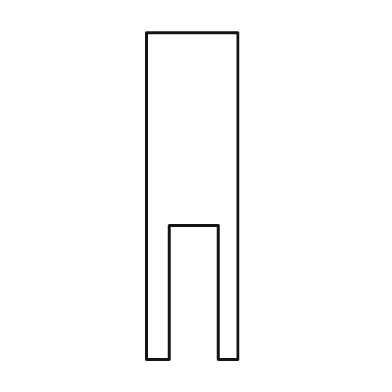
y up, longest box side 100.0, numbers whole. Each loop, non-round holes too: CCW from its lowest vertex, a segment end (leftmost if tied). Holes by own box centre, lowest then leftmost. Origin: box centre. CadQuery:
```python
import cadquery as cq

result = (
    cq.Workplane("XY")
    .moveTo(-14.0, -50.0)
    .lineTo(-7.0, -50.0)
    .lineTo(-7.0, -9.0)
    .lineTo(8.0, -9.0)
    .lineTo(8.0, -50.0)
    .lineTo(14.0, -50.0)
    .lineTo(14.0, 50.0)
    .lineTo(-14.0, 50.0)
    .close()
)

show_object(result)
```